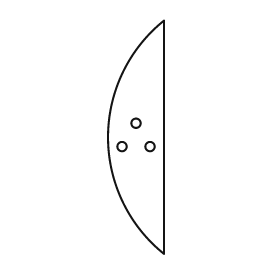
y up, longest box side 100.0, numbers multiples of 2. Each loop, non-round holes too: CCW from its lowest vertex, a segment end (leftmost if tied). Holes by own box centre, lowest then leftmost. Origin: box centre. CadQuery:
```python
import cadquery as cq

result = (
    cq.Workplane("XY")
    .moveTo(12.0, -50.0)
    .lineTo(12.0, 50.0)
    .threePointArc((-12.0, 0.0), (12.0, -50.0))
    .close()
    .moveTo(-6.0, -4.0)
    .circle(2.0)
    .moveTo(6.0, -4.0)
    .circle(2.0)
    .moveTo(0.0, 6.0)
    .circle(2.0)
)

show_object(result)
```